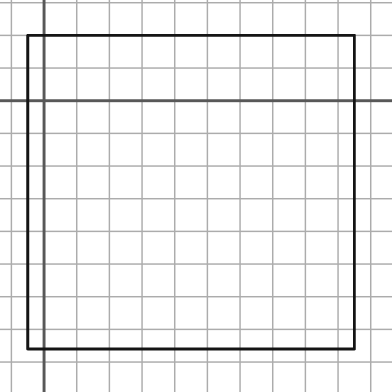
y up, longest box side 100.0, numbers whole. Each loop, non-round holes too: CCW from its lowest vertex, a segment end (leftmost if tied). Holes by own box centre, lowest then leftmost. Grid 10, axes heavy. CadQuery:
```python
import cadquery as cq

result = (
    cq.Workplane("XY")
    .moveTo(-5.0, -76.0)
    .lineTo(95.0, -76.0)
    .lineTo(95.0, 20.0)
    .lineTo(-5.0, 20.0)
    .close()
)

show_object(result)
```